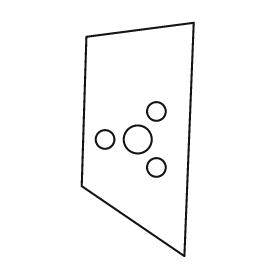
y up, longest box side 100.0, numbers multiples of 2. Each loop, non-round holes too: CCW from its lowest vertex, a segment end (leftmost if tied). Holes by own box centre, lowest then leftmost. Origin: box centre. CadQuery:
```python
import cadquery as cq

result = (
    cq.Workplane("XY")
    .moveTo(20.0, -50.0)
    .lineTo(24.0, 50.0)
    .lineTo(-22.0, 44.0)
    .lineTo(-24.0, -20.0)
    .close()
    .moveTo(8.0, -12.0)
    .circle(4.0)
    .moveTo(-14.0, 0.0)
    .circle(4.0)
    .moveTo(0.0, 0.0)
    .circle(6.0)
    .moveTo(8.0, 12.0)
    .circle(4.0)
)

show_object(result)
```